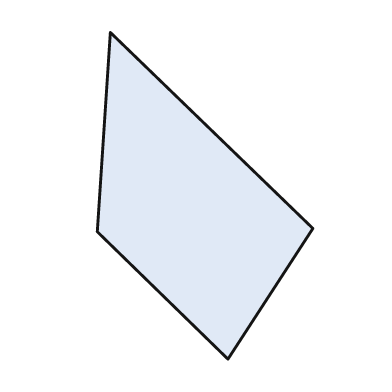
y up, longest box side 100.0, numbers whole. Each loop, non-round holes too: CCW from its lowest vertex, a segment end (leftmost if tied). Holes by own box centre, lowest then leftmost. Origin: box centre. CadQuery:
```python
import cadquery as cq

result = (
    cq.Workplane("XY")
    .moveTo(7.0, -50.0)
    .lineTo(33.0, -10.0)
    .lineTo(-29.0, 50.0)
    .lineTo(-33.0, -11.0)
    .close()
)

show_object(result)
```